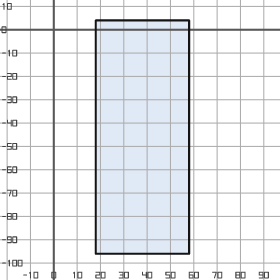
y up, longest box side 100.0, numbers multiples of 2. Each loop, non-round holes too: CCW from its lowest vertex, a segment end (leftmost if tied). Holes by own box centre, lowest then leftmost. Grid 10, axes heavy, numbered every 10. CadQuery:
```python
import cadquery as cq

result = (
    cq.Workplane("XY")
    .moveTo(18.0, -96.0)
    .lineTo(58.0, -96.0)
    .lineTo(58.0, 4.0)
    .lineTo(18.0, 4.0)
    .close()
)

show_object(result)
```